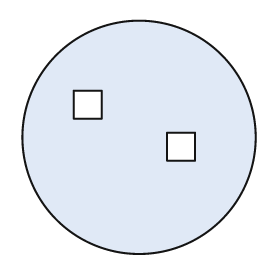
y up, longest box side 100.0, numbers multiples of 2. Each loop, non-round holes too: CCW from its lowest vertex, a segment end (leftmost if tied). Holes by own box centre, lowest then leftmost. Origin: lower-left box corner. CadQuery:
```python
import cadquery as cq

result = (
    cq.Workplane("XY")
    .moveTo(50.0, 50.0)
    .circle(50.0)
    .moveTo(62.0, 40.0)
    .lineTo(74.0, 40.0)
    .lineTo(74.0, 52.0)
    .lineTo(62.0, 52.0)
    .close()
    .moveTo(22.0, 58.0)
    .lineTo(34.0, 58.0)
    .lineTo(34.0, 70.0)
    .lineTo(22.0, 70.0)
    .close()
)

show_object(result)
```